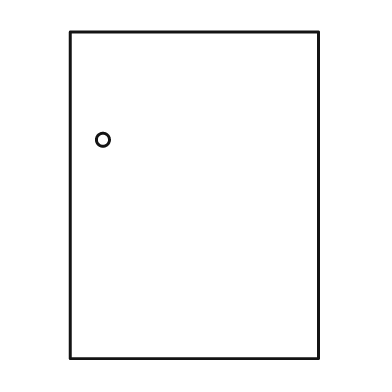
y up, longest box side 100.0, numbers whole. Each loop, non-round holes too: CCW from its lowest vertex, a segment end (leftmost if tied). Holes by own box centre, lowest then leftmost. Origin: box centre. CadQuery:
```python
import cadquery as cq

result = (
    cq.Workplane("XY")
    .moveTo(-38.0, -50.0)
    .lineTo(38.0, -50.0)
    .lineTo(38.0, 50.0)
    .lineTo(-38.0, 50.0)
    .close()
    .moveTo(-28.0, 17.0)
    .circle(2.0)
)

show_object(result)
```